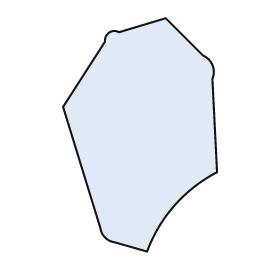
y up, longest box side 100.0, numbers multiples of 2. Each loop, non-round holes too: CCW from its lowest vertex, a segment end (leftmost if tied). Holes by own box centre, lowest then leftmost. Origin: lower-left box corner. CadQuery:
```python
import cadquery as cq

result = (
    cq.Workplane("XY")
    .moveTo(36.0, 0.0)
    .threePointArc((48.0, 20.0), (66.0, 34.0))
    .lineTo(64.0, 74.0)
    .threePointArc((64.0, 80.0), (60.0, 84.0))
    .lineTo(44.0, 100.0)
    .lineTo(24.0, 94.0)
    .threePointArc((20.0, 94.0), (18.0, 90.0))
    .lineTo(0.0, 62.0)
    .lineTo(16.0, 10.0)
    .threePointArc((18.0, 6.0), (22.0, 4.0))
    .close()
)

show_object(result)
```